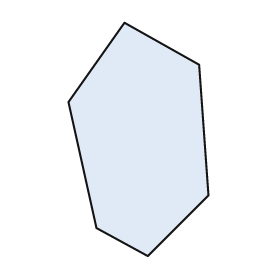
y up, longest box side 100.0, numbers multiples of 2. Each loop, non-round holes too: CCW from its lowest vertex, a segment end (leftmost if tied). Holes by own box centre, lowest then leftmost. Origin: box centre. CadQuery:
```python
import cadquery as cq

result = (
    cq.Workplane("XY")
    .moveTo(4.0, -50.0)
    .lineTo(30.0, -24.0)
    .lineTo(26.0, 32.0)
    .lineTo(-6.0, 50.0)
    .lineTo(-30.0, 16.0)
    .lineTo(-18.0, -38.0)
    .close()
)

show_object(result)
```